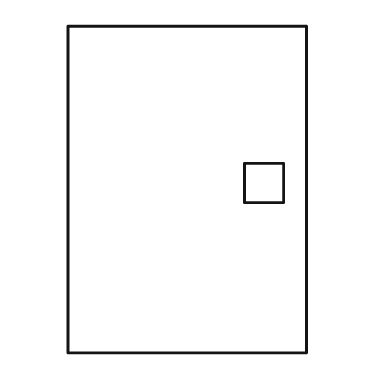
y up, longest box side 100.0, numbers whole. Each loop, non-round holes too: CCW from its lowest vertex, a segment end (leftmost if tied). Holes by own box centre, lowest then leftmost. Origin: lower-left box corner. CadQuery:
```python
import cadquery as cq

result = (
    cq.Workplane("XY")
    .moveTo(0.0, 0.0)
    .lineTo(73.0, 0.0)
    .lineTo(73.0, 100.0)
    .lineTo(0.0, 100.0)
    .close()
    .moveTo(54.0, 46.0)
    .lineTo(66.0, 46.0)
    .lineTo(66.0, 58.0)
    .lineTo(54.0, 58.0)
    .close()
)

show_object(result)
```